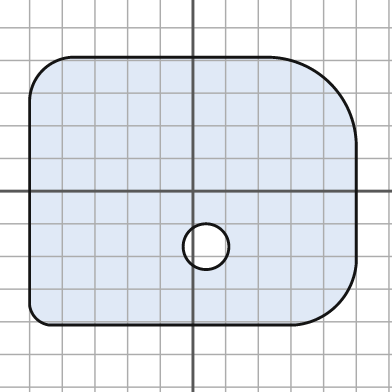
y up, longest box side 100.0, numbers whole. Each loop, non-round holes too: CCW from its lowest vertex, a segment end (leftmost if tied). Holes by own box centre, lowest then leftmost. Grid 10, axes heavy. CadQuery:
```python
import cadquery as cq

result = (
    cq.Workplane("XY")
    .moveTo(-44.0, -41.0)
    .lineTo(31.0, -41.0)
    .threePointArc((44.0, -35.0), (50.0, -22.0))
    .lineTo(50.0, 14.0)
    .threePointArc((42.0, 33.0), (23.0, 41.0))
    .lineTo(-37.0, 41.0)
    .threePointArc((-46.0, 37.0), (-50.0, 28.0))
    .lineTo(-50.0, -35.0)
    .threePointArc((-48.0, -39.0), (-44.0, -41.0))
    .close()
    .moveTo(4.0, -17.0)
    .circle(7.0)
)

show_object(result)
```